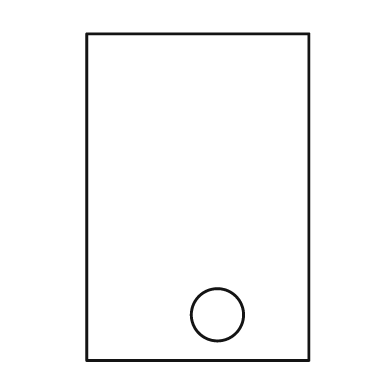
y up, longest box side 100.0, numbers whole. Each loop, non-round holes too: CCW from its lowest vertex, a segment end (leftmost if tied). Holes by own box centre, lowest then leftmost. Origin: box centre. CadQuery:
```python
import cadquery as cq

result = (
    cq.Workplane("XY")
    .moveTo(-34.0, -50.0)
    .lineTo(34.0, -50.0)
    .lineTo(34.0, 50.0)
    .lineTo(-34.0, 50.0)
    .close()
    .moveTo(6.0, -36.0)
    .circle(8.0)
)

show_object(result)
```